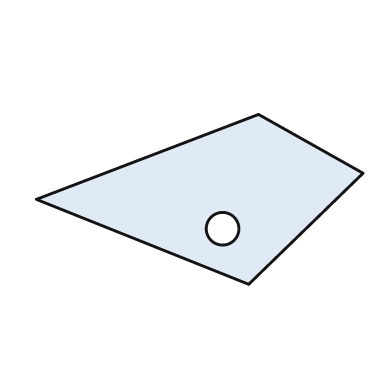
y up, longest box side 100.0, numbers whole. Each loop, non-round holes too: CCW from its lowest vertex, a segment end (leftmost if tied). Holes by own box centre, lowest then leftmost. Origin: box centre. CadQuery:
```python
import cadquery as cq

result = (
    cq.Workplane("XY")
    .moveTo(15.0, -26.0)
    .lineTo(50.0, 8.0)
    .lineTo(18.0, 26.0)
    .lineTo(-50.0, 0.0)
    .close()
    .moveTo(7.0, -9.0)
    .circle(5.0)
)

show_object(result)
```